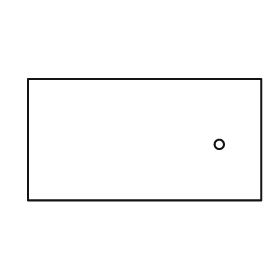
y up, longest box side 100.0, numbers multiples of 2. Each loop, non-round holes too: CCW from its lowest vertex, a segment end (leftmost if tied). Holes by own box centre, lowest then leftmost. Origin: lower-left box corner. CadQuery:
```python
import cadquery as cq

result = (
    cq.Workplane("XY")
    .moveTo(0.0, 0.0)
    .lineTo(100.0, 0.0)
    .lineTo(100.0, 52.0)
    .lineTo(0.0, 52.0)
    .close()
    .moveTo(82.0, 24.0)
    .circle(2.0)
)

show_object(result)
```